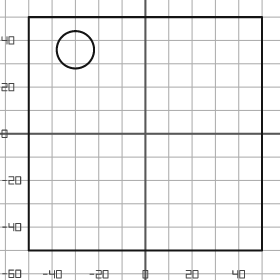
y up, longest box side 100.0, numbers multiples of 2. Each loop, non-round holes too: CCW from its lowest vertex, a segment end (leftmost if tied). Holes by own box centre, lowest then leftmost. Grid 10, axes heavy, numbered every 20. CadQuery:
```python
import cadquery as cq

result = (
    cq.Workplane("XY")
    .moveTo(-50.0, -50.0)
    .lineTo(50.0, -50.0)
    .lineTo(50.0, 50.0)
    .lineTo(-50.0, 50.0)
    .close()
    .moveTo(-30.0, 36.0)
    .circle(8.0)
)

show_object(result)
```